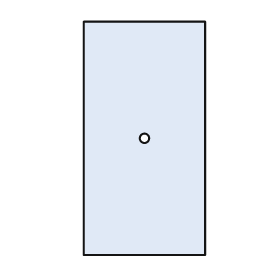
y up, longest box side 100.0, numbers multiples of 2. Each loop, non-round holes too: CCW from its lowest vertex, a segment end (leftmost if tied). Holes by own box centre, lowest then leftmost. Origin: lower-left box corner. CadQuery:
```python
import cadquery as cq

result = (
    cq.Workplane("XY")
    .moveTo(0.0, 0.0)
    .lineTo(52.0, 0.0)
    .lineTo(52.0, 100.0)
    .lineTo(0.0, 100.0)
    .close()
    .moveTo(26.0, 50.0)
    .circle(2.0)
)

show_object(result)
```